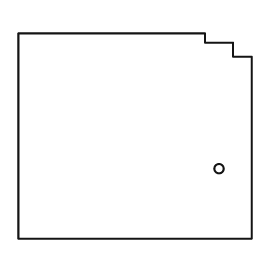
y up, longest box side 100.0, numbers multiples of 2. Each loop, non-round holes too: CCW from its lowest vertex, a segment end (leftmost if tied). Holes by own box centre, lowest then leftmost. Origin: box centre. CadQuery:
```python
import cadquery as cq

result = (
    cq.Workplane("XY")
    .moveTo(-50.0, -44.0)
    .lineTo(50.0, -44.0)
    .lineTo(50.0, 34.0)
    .lineTo(42.0, 34.0)
    .lineTo(42.0, 40.0)
    .lineTo(30.0, 40.0)
    .lineTo(30.0, 44.0)
    .lineTo(-50.0, 44.0)
    .close()
    .moveTo(36.0, -14.0)
    .circle(2.0)
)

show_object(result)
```